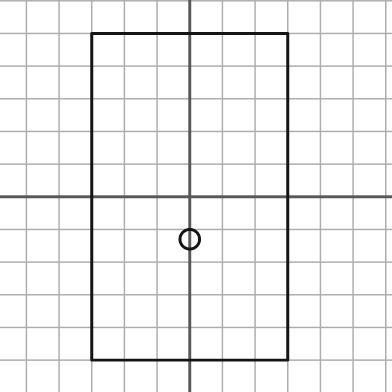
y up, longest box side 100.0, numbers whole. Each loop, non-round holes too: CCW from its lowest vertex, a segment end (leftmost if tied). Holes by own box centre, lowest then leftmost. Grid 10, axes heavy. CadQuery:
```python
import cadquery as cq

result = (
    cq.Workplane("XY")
    .moveTo(-30.0, -50.0)
    .lineTo(30.0, -50.0)
    .lineTo(30.0, 50.0)
    .lineTo(-30.0, 50.0)
    .close()
    .moveTo(0.0, -13.0)
    .circle(3.0)
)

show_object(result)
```